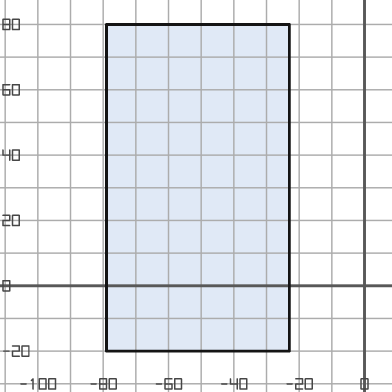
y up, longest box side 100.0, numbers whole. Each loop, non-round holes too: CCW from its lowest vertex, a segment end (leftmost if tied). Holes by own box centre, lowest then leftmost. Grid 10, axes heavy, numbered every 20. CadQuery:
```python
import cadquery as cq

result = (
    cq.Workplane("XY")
    .moveTo(-79.0, -20.0)
    .lineTo(-23.0, -20.0)
    .lineTo(-23.0, 80.0)
    .lineTo(-79.0, 80.0)
    .close()
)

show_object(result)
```